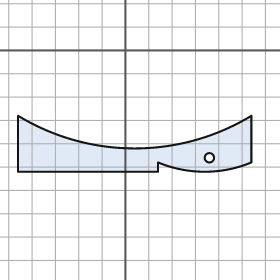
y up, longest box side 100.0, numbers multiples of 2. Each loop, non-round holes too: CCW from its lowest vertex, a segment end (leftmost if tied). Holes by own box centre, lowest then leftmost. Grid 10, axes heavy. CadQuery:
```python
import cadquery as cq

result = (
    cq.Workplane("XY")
    .moveTo(-46.0, -52.0)
    .lineTo(14.0, -52.0)
    .lineTo(14.0, -48.0)
    .threePointArc((34.0, -52.0), (54.0, -48.0))
    .lineTo(54.0, -28.0)
    .threePointArc((4.0, -42.0), (-46.0, -28.0))
    .close()
    .moveTo(36.0, -46.0)
    .circle(2.0)
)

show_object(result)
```